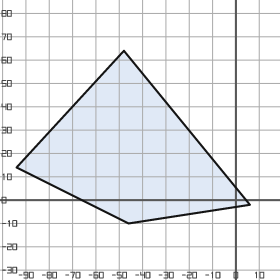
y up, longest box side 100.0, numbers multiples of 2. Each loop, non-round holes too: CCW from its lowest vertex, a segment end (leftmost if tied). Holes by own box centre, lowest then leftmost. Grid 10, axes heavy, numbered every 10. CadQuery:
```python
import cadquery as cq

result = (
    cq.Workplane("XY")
    .moveTo(-46.0, -10.0)
    .lineTo(6.0, -2.0)
    .lineTo(-48.0, 64.0)
    .lineTo(-94.0, 14.0)
    .close()
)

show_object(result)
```